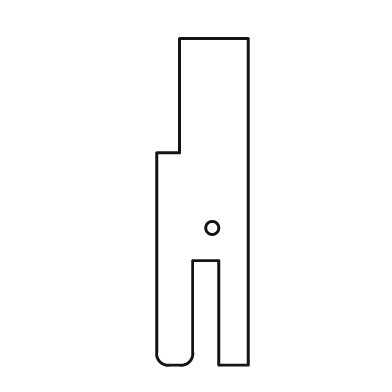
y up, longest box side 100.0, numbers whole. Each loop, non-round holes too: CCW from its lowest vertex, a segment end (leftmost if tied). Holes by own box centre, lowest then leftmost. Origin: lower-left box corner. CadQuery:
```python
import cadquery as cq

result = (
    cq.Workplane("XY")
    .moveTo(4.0, 0.0)
    .lineTo(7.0, 0.0)
    .threePointArc((10.0, 1.0), (11.0, 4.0))
    .lineTo(11.0, 32.0)
    .lineTo(19.0, 32.0)
    .lineTo(19.0, 0.0)
    .lineTo(28.0, 0.0)
    .lineTo(28.0, 100.0)
    .lineTo(7.0, 100.0)
    .lineTo(7.0, 65.0)
    .lineTo(0.0, 65.0)
    .lineTo(0.0, 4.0)
    .threePointArc((1.0, 1.0), (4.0, 0.0))
    .close()
    .moveTo(17.0, 42.0)
    .circle(2.0)
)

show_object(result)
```